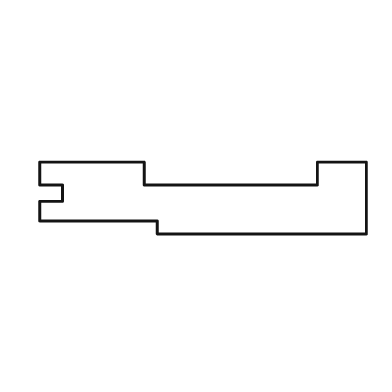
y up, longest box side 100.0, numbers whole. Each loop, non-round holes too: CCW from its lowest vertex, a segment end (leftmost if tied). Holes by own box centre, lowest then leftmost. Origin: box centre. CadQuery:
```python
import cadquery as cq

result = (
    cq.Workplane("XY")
    .moveTo(-14.0, -11.0)
    .lineTo(50.0, -11.0)
    .lineTo(50.0, 11.0)
    .lineTo(35.0, 11.0)
    .lineTo(35.0, 4.0)
    .lineTo(-18.0, 4.0)
    .lineTo(-18.0, 11.0)
    .lineTo(-50.0, 11.0)
    .lineTo(-50.0, 4.0)
    .lineTo(-43.0, 4.0)
    .lineTo(-43.0, -1.0)
    .lineTo(-50.0, -1.0)
    .lineTo(-50.0, -7.0)
    .lineTo(-14.0, -7.0)
    .close()
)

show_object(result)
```